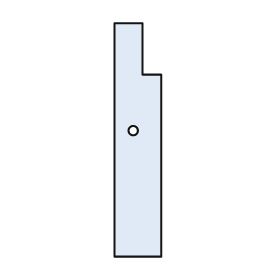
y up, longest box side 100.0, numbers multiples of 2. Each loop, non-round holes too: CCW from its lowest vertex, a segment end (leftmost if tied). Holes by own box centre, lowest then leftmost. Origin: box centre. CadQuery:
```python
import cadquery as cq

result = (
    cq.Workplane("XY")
    .moveTo(-10.0, -50.0)
    .lineTo(10.0, -50.0)
    .lineTo(10.0, 28.0)
    .lineTo(2.0, 28.0)
    .lineTo(2.0, 50.0)
    .lineTo(-10.0, 50.0)
    .close()
    .moveTo(-2.0, 4.0)
    .circle(2.0)
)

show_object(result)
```